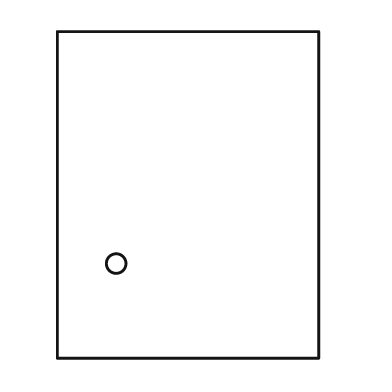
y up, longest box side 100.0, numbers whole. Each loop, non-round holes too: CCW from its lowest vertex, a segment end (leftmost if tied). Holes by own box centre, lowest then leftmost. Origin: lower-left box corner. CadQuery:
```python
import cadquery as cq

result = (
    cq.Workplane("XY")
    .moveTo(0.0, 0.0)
    .lineTo(80.0, 0.0)
    .lineTo(80.0, 100.0)
    .lineTo(0.0, 100.0)
    .close()
    .moveTo(18.0, 29.0)
    .circle(3.0)
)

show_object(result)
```